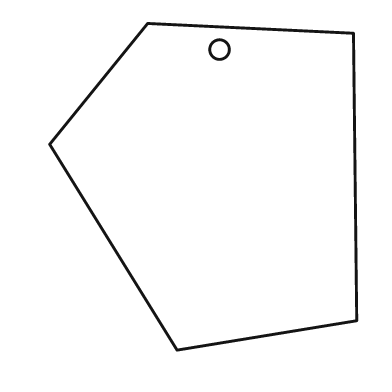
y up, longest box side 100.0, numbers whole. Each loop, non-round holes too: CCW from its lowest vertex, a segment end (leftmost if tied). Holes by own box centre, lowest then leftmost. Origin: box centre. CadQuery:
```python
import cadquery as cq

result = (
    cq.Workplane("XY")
    .moveTo(-8.0, -50.0)
    .lineTo(47.0, -41.0)
    .lineTo(46.0, 47.0)
    .lineTo(-17.0, 50.0)
    .lineTo(-47.0, 13.0)
    .close()
    .moveTo(5.0, 42.0)
    .circle(3.0)
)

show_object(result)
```